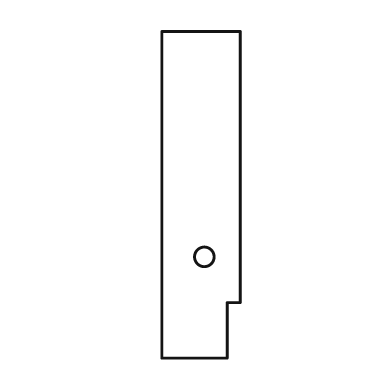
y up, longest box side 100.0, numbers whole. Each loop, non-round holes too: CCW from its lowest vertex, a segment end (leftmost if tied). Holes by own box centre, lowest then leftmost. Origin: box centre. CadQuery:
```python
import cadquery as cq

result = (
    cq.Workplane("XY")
    .moveTo(-12.0, -50.0)
    .lineTo(8.0, -50.0)
    .lineTo(8.0, -33.0)
    .lineTo(12.0, -33.0)
    .lineTo(12.0, 50.0)
    .lineTo(-12.0, 50.0)
    .close()
    .moveTo(1.0, -19.0)
    .circle(3.0)
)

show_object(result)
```